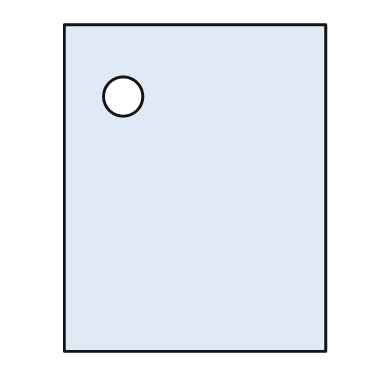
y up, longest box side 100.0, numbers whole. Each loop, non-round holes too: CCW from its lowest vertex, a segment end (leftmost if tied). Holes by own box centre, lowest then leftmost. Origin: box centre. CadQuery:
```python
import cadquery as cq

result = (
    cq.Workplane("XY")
    .moveTo(-40.0, -50.0)
    .lineTo(40.0, -50.0)
    .lineTo(40.0, 50.0)
    .lineTo(-40.0, 50.0)
    .close()
    .moveTo(-22.0, 28.0)
    .circle(6.0)
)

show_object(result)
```